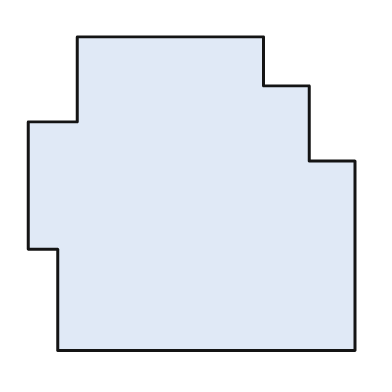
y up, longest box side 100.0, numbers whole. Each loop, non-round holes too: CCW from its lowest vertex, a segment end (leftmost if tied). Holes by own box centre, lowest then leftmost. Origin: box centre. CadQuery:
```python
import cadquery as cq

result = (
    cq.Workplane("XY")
    .moveTo(-41.0, -48.0)
    .lineTo(50.0, -48.0)
    .lineTo(50.0, 10.0)
    .lineTo(36.0, 10.0)
    .lineTo(36.0, 33.0)
    .lineTo(22.0, 33.0)
    .lineTo(22.0, 48.0)
    .lineTo(-35.0, 48.0)
    .lineTo(-35.0, 22.0)
    .lineTo(-50.0, 22.0)
    .lineTo(-50.0, -17.0)
    .lineTo(-41.0, -17.0)
    .close()
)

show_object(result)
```